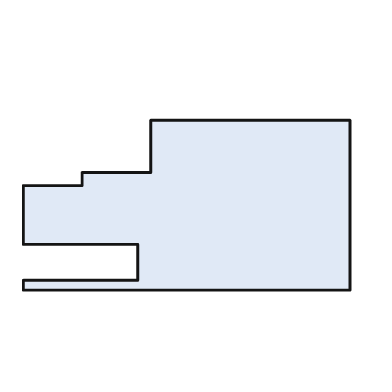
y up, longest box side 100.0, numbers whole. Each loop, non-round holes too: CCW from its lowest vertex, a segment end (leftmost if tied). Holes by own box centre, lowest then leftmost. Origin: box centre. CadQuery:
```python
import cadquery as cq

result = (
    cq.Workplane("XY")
    .moveTo(-50.0, -26.0)
    .lineTo(50.0, -26.0)
    .lineTo(50.0, 26.0)
    .lineTo(-11.0, 26.0)
    .lineTo(-11.0, 10.0)
    .lineTo(-32.0, 10.0)
    .lineTo(-32.0, 6.0)
    .lineTo(-50.0, 6.0)
    .lineTo(-50.0, -12.0)
    .lineTo(-15.0, -12.0)
    .lineTo(-15.0, -23.0)
    .lineTo(-50.0, -23.0)
    .close()
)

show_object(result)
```